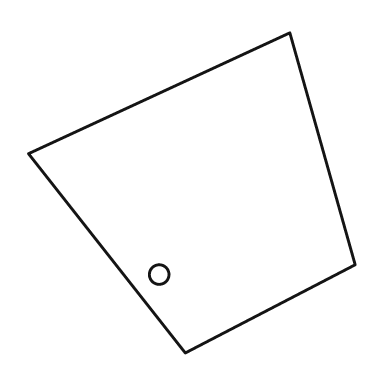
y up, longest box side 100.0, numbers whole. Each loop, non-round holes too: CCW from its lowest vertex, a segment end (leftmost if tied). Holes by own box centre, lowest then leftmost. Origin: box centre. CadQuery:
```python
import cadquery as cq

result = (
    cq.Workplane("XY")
    .moveTo(-2.0, -49.0)
    .lineTo(50.0, -22.0)
    .lineTo(30.0, 49.0)
    .lineTo(-50.0, 12.0)
    .close()
    .moveTo(-10.0, -25.0)
    .circle(3.0)
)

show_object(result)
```